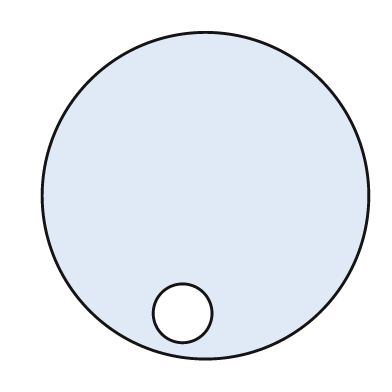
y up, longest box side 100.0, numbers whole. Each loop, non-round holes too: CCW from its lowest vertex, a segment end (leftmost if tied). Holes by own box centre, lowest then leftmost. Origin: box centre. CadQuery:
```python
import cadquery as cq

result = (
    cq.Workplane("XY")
    .moveTo(0.0, 0.0)
    .circle(50.0)
    .moveTo(-7.0, -36.0)
    .circle(9.0)
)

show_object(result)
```